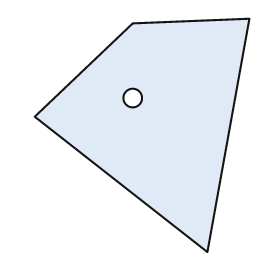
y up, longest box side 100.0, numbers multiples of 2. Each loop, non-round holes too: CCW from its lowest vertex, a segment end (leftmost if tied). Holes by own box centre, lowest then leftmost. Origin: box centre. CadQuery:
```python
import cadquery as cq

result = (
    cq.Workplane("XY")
    .moveTo(28.0, -50.0)
    .lineTo(46.0, 50.0)
    .lineTo(-4.0, 48.0)
    .lineTo(-46.0, 8.0)
    .close()
    .moveTo(-4.0, 16.0)
    .circle(4.0)
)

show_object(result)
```